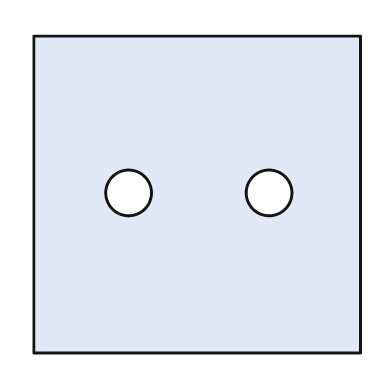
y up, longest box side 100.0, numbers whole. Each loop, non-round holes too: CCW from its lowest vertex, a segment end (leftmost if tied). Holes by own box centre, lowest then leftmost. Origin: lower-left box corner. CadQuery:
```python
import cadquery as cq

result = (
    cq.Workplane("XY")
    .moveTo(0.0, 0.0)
    .lineTo(100.0, 0.0)
    .lineTo(100.0, 97.0)
    .lineTo(0.0, 97.0)
    .close()
    .moveTo(29.0, 49.0)
    .circle(7.0)
    .moveTo(72.0, 49.0)
    .circle(7.0)
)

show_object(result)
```